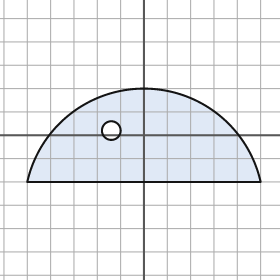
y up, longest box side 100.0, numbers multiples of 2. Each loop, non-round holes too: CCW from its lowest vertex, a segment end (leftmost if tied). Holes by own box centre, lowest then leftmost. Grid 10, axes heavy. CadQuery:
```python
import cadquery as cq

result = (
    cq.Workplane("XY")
    .moveTo(-50.0, -20.0)
    .lineTo(50.0, -20.0)
    .threePointArc((0.0, 20.0), (-50.0, -20.0))
    .close()
    .moveTo(-14.0, 2.0)
    .circle(4.0)
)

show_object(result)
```